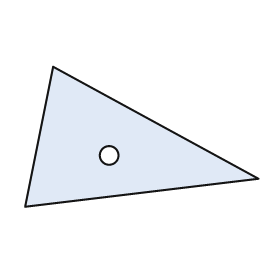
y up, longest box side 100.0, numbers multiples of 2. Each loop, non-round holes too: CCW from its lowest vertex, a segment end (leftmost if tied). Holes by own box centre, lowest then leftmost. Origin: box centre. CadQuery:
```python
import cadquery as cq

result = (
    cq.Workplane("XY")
    .moveTo(-50.0, -30.0)
    .lineTo(50.0, -18.0)
    .lineTo(-38.0, 30.0)
    .close()
    .moveTo(-14.0, -8.0)
    .circle(4.0)
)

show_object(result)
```